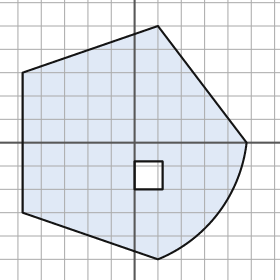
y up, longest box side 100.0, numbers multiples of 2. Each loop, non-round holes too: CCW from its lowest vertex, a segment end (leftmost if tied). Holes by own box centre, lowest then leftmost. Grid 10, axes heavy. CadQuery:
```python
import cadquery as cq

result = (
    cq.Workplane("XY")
    .moveTo(10.0, -50.0)
    .threePointArc((36.0, -30.0), (48.0, 0.0))
    .lineTo(10.0, 50.0)
    .lineTo(-48.0, 30.0)
    .lineTo(-48.0, -30.0)
    .close()
    .moveTo(0.0, -20.0)
    .lineTo(12.0, -20.0)
    .lineTo(12.0, -8.0)
    .lineTo(0.0, -8.0)
    .close()
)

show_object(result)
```